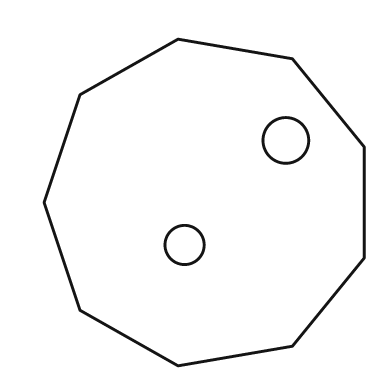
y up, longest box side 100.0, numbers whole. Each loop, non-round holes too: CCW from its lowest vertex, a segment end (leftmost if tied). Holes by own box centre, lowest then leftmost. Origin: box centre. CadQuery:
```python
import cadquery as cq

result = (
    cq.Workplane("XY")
    .moveTo(-8.0, -50.0)
    .lineTo(27.0, -44.0)
    .lineTo(49.0, -17.0)
    .lineTo(49.0, 17.0)
    .lineTo(27.0, 44.0)
    .lineTo(-8.0, 50.0)
    .lineTo(-38.0, 33.0)
    .lineTo(-49.0, 0.0)
    .lineTo(-38.0, -33.0)
    .close()
    .moveTo(-6.0, -13.0)
    .circle(6.0)
    .moveTo(25.0, 19.0)
    .circle(7.0)
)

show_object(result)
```